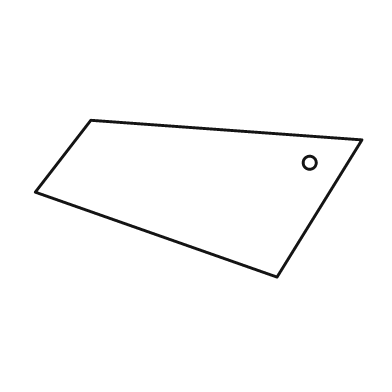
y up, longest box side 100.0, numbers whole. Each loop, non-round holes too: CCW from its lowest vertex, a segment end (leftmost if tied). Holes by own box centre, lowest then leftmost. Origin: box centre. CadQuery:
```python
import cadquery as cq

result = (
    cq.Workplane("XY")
    .moveTo(24.0, -24.0)
    .lineTo(50.0, 18.0)
    .lineTo(-33.0, 24.0)
    .lineTo(-50.0, 2.0)
    .close()
    .moveTo(34.0, 11.0)
    .circle(2.0)
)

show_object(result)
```